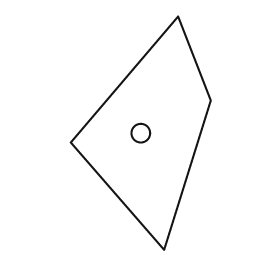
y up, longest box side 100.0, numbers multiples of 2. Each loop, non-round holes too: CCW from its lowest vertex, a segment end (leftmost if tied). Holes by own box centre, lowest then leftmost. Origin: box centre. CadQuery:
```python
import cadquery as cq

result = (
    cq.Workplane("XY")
    .moveTo(10.0, -50.0)
    .lineTo(30.0, 14.0)
    .lineTo(16.0, 50.0)
    .lineTo(-30.0, -4.0)
    .close()
    .moveTo(0.0, 0.0)
    .circle(4.0)
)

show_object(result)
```